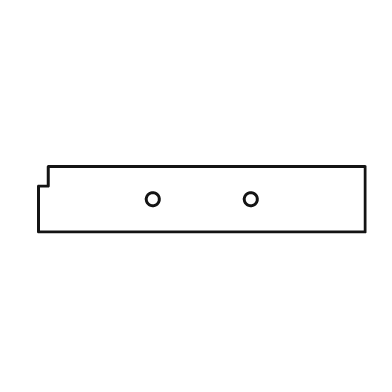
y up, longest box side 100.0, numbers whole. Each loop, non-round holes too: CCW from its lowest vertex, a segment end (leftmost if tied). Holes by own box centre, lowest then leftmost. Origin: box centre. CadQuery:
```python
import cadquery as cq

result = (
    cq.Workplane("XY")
    .moveTo(-50.0, -10.0)
    .lineTo(50.0, -10.0)
    .lineTo(50.0, 10.0)
    .lineTo(-47.0, 10.0)
    .lineTo(-47.0, 4.0)
    .lineTo(-50.0, 4.0)
    .close()
    .moveTo(-15.0, 0.0)
    .circle(2.0)
    .moveTo(15.0, 0.0)
    .circle(2.0)
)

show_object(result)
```